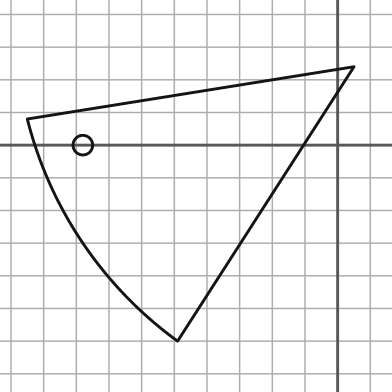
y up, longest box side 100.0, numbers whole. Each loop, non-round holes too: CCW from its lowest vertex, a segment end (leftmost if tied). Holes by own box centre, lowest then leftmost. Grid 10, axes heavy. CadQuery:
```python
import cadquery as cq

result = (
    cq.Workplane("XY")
    .moveTo(-49.0, -60.0)
    .lineTo(5.0, 24.0)
    .lineTo(-95.0, 8.0)
    .threePointArc((-78.0, -30.0), (-49.0, -60.0))
    .close()
    .moveTo(-78.0, 0.0)
    .circle(3.0)
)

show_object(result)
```